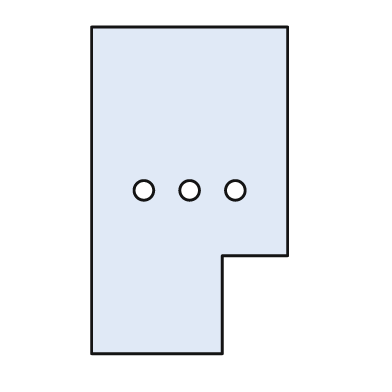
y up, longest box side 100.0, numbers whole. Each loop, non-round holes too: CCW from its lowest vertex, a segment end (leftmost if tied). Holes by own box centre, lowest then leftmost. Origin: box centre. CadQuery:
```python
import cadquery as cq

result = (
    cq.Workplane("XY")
    .moveTo(-30.0, -50.0)
    .lineTo(10.0, -50.0)
    .lineTo(10.0, -20.0)
    .lineTo(30.0, -20.0)
    .lineTo(30.0, 50.0)
    .lineTo(-30.0, 50.0)
    .close()
    .moveTo(-14.0, 0.0)
    .circle(3.0)
    .moveTo(0.0, 0.0)
    .circle(3.0)
    .moveTo(14.0, 0.0)
    .circle(3.0)
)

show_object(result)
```